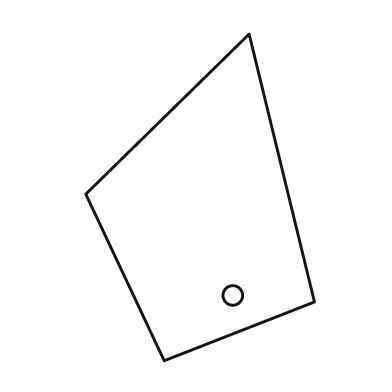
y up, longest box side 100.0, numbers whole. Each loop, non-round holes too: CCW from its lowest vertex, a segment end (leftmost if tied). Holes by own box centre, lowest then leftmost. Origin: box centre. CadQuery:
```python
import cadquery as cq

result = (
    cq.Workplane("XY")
    .moveTo(-11.0, -50.0)
    .lineTo(35.0, -32.0)
    .lineTo(15.0, 50.0)
    .lineTo(-35.0, 1.0)
    .close()
    .moveTo(10.0, -30.0)
    .circle(3.0)
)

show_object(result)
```